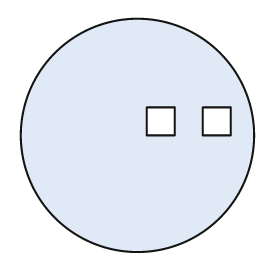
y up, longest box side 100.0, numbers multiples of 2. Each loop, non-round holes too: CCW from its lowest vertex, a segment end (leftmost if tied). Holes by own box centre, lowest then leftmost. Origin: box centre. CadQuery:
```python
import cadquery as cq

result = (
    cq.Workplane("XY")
    .moveTo(0.0, 0.0)
    .circle(50.0)
    .moveTo(4.0, 0.0)
    .lineTo(16.0, 0.0)
    .lineTo(16.0, 12.0)
    .lineTo(4.0, 12.0)
    .close()
    .moveTo(28.0, 0.0)
    .lineTo(40.0, 0.0)
    .lineTo(40.0, 12.0)
    .lineTo(28.0, 12.0)
    .close()
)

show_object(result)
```